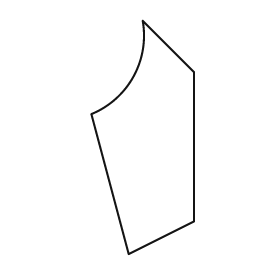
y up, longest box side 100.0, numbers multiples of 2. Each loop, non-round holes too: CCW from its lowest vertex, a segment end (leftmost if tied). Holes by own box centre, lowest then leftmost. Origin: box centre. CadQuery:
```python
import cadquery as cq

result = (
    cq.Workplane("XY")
    .moveTo(-6.0, -50.0)
    .lineTo(22.0, -36.0)
    .lineTo(22.0, 28.0)
    .lineTo(0.0, 50.0)
    .threePointArc((-4.0, 26.0), (-22.0, 10.0))
    .close()
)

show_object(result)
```